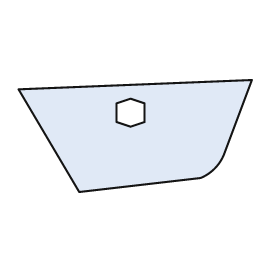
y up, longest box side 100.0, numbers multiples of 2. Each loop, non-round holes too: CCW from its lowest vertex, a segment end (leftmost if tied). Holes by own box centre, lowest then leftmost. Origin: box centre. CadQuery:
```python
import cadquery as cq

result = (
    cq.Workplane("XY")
    .moveTo(-24.0, -24.0)
    .lineTo(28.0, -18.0)
    .threePointArc((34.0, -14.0), (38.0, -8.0))
    .lineTo(50.0, 24.0)
    .lineTo(-50.0, 20.0)
    .close()
    .moveTo(-2.0, 4.0)
    .lineTo(4.0, 6.0)
    .lineTo(4.0, 14.0)
    .lineTo(-2.0, 16.0)
    .lineTo(-8.0, 14.0)
    .lineTo(-8.0, 6.0)
    .close()
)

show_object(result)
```